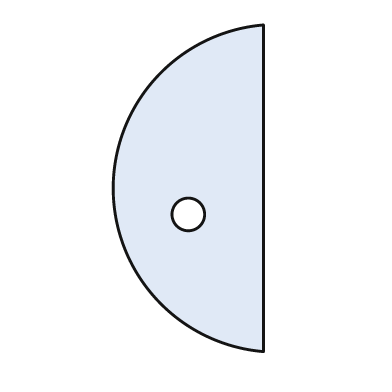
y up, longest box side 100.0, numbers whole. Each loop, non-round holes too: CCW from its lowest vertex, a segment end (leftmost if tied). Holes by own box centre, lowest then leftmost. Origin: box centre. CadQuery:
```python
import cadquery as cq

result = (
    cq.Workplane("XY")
    .moveTo(23.0, -50.0)
    .lineTo(23.0, 50.0)
    .threePointArc((-23.0, 0.0), (23.0, -50.0))
    .close()
    .moveTo(0.0, -8.0)
    .circle(5.0)
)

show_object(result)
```